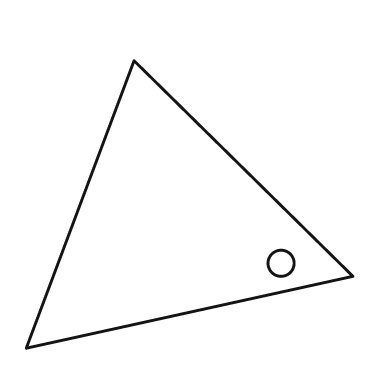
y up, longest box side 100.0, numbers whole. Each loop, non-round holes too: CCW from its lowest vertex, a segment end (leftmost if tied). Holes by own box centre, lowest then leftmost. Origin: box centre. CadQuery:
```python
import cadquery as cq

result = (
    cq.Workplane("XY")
    .moveTo(-50.0, -44.0)
    .lineTo(50.0, -22.0)
    .lineTo(-17.0, 44.0)
    .close()
    .moveTo(28.0, -18.0)
    .circle(4.0)
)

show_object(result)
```